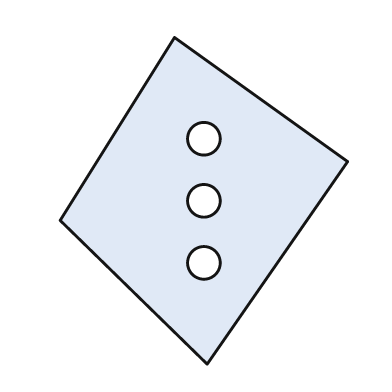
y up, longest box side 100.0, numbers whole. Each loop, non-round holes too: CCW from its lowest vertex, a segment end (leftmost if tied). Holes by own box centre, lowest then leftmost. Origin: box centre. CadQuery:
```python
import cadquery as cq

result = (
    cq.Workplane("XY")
    .moveTo(1.0, -50.0)
    .lineTo(44.0, 12.0)
    .lineTo(-9.0, 50.0)
    .lineTo(-44.0, -6.0)
    .close()
    .moveTo(0.0, -19.0)
    .circle(5.0)
    .moveTo(0.0, 0.0)
    .circle(5.0)
    .moveTo(0.0, 19.0)
    .circle(5.0)
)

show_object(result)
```